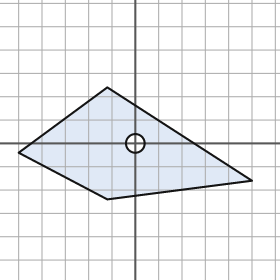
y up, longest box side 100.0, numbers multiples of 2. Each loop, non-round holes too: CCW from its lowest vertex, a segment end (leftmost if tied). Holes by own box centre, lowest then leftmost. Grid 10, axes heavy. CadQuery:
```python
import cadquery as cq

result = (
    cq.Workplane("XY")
    .moveTo(-12.0, -24.0)
    .lineTo(50.0, -16.0)
    .lineTo(-12.0, 24.0)
    .lineTo(-50.0, -4.0)
    .close()
    .moveTo(0.0, 0.0)
    .circle(4.0)
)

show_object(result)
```